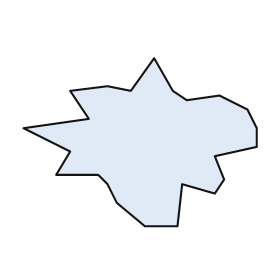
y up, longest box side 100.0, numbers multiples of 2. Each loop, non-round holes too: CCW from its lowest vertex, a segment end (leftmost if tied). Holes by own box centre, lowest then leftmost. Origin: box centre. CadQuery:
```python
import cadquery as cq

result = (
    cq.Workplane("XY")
    .moveTo(2.0, -36.0)
    .lineTo(16.0, -36.0)
    .lineTo(18.0, -18.0)
    .lineTo(32.0, -22.0)
    .lineTo(36.0, -16.0)
    .lineTo(32.0, -6.0)
    .lineTo(50.0, -2.0)
    .lineTo(50.0, 6.0)
    .lineTo(46.0, 14.0)
    .lineTo(34.0, 20.0)
    .lineTo(20.0, 18.0)
    .lineTo(14.0, 22.0)
    .lineTo(6.0, 36.0)
    .lineTo(-4.0, 22.0)
    .lineTo(-14.0, 24.0)
    .lineTo(-30.0, 22.0)
    .lineTo(-22.0, 10.0)
    .lineTo(-50.0, 6.0)
    .lineTo(-30.0, -4.0)
    .lineTo(-36.0, -14.0)
    .lineTo(-18.0, -14.0)
    .lineTo(-14.0, -18.0)
    .lineTo(-10.0, -26.0)
    .close()
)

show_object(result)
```